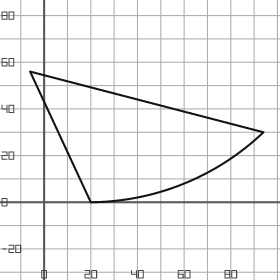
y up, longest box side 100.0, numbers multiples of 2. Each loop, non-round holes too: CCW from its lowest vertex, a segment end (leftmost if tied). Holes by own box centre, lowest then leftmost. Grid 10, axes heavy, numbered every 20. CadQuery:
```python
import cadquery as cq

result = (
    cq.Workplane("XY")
    .moveTo(20.0, 0.0)
    .threePointArc((60.0, 8.0), (94.0, 30.0))
    .lineTo(-6.0, 56.0)
    .close()
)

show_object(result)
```